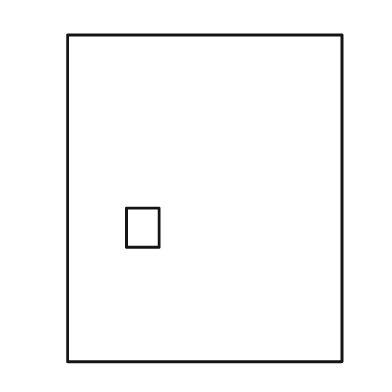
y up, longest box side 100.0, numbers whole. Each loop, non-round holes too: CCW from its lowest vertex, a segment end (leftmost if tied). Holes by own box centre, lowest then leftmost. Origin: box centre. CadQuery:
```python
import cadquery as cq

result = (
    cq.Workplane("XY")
    .moveTo(-42.0, -50.0)
    .lineTo(42.0, -50.0)
    .lineTo(42.0, 50.0)
    .lineTo(-42.0, 50.0)
    .close()
    .moveTo(-24.0, -15.0)
    .lineTo(-14.0, -15.0)
    .lineTo(-14.0, -3.0)
    .lineTo(-24.0, -3.0)
    .close()
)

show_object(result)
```